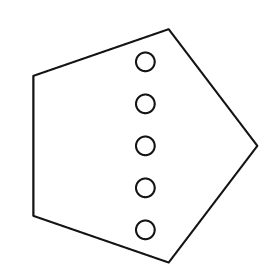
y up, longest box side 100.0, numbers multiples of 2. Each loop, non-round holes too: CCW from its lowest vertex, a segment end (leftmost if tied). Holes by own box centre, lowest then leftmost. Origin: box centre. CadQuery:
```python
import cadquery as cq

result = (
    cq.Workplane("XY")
    .moveTo(10.0, -50.0)
    .lineTo(48.0, 0.0)
    .lineTo(10.0, 50.0)
    .lineTo(-48.0, 30.0)
    .lineTo(-48.0, -30.0)
    .close()
    .moveTo(0.0, -36.0)
    .circle(4.0)
    .moveTo(0.0, -18.0)
    .circle(4.0)
    .moveTo(0.0, 0.0)
    .circle(4.0)
    .moveTo(0.0, 18.0)
    .circle(4.0)
    .moveTo(0.0, 36.0)
    .circle(4.0)
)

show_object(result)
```